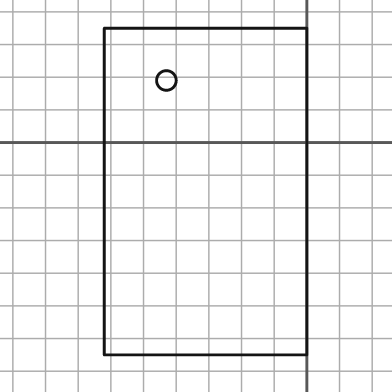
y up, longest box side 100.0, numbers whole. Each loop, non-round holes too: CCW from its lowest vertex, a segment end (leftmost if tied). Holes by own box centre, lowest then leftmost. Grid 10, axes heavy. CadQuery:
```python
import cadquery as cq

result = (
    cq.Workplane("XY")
    .moveTo(-62.0, -65.0)
    .lineTo(0.0, -65.0)
    .lineTo(0.0, 35.0)
    .lineTo(-62.0, 35.0)
    .close()
    .moveTo(-43.0, 19.0)
    .circle(3.0)
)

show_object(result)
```